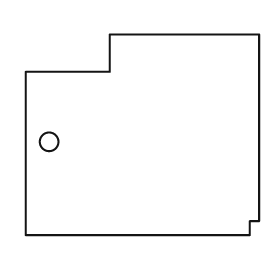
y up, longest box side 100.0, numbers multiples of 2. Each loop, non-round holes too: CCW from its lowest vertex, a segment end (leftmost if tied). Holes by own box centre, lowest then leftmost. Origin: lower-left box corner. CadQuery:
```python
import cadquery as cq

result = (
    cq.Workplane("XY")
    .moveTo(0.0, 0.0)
    .lineTo(96.0, 0.0)
    .lineTo(96.0, 6.0)
    .lineTo(100.0, 6.0)
    .lineTo(100.0, 86.0)
    .lineTo(36.0, 86.0)
    .lineTo(36.0, 70.0)
    .lineTo(0.0, 70.0)
    .close()
    .moveTo(10.0, 40.0)
    .circle(4.0)
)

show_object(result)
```